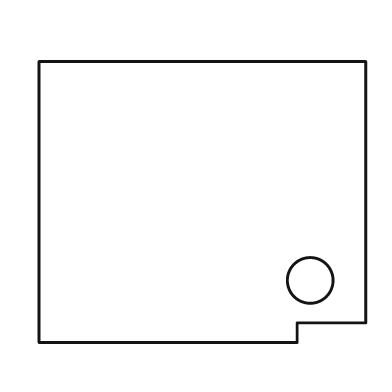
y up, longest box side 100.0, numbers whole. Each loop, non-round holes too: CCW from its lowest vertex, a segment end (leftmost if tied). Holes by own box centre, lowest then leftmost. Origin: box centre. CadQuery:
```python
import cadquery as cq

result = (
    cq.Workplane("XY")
    .moveTo(-50.0, -43.0)
    .lineTo(29.0, -43.0)
    .lineTo(29.0, -37.0)
    .lineTo(50.0, -37.0)
    .lineTo(50.0, 43.0)
    .lineTo(-50.0, 43.0)
    .close()
    .moveTo(33.0, -24.0)
    .circle(7.0)
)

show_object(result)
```